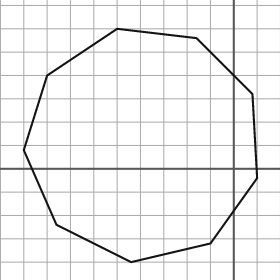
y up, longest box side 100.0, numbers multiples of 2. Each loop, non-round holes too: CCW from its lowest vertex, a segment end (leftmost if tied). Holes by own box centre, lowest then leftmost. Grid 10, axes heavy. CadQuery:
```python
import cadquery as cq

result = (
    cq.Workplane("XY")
    .moveTo(-44.0, -40.0)
    .lineTo(-10.0, -32.0)
    .lineTo(10.0, -4.0)
    .lineTo(8.0, 32.0)
    .lineTo(-16.0, 56.0)
    .lineTo(-50.0, 60.0)
    .lineTo(-80.0, 40.0)
    .lineTo(-90.0, 8.0)
    .lineTo(-76.0, -24.0)
    .close()
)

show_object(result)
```